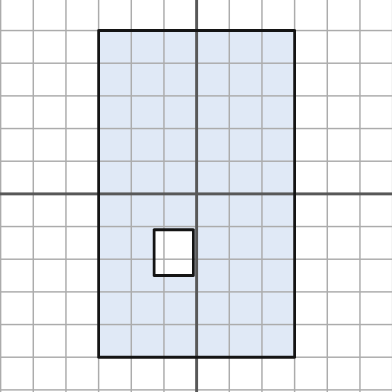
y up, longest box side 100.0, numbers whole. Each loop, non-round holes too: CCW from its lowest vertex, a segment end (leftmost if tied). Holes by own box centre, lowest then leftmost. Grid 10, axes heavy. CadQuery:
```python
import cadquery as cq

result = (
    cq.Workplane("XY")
    .moveTo(-30.0, -50.0)
    .lineTo(30.0, -50.0)
    .lineTo(30.0, 50.0)
    .lineTo(-30.0, 50.0)
    .close()
    .moveTo(-13.0, -25.0)
    .lineTo(-1.0, -25.0)
    .lineTo(-1.0, -11.0)
    .lineTo(-13.0, -11.0)
    .close()
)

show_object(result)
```